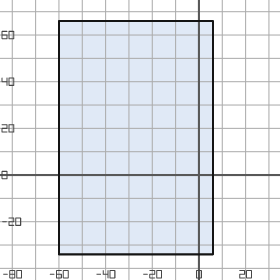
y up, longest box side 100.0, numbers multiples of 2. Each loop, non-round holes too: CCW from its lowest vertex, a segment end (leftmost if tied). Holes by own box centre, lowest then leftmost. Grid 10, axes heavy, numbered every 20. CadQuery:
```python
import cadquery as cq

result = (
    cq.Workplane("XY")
    .moveTo(-60.0, -34.0)
    .lineTo(6.0, -34.0)
    .lineTo(6.0, 66.0)
    .lineTo(-60.0, 66.0)
    .close()
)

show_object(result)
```